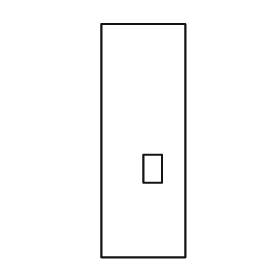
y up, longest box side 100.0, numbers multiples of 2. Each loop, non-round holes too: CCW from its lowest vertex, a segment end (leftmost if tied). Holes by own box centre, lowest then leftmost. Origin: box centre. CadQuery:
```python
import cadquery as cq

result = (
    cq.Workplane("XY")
    .moveTo(-18.0, -50.0)
    .lineTo(18.0, -50.0)
    .lineTo(18.0, 50.0)
    .lineTo(-18.0, 50.0)
    .close()
    .moveTo(0.0, -18.0)
    .lineTo(8.0, -18.0)
    .lineTo(8.0, -6.0)
    .lineTo(0.0, -6.0)
    .close()
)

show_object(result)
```